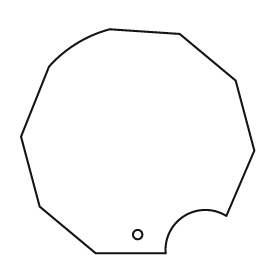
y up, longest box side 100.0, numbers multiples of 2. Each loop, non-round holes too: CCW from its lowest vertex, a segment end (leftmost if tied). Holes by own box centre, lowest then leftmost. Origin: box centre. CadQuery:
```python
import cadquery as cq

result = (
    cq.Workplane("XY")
    .moveTo(-18.0, -48.0)
    .lineTo(12.0, -48.0)
    .threePointArc((20.0, -32.0), (38.0, -32.0))
    .lineTo(50.0, -4.0)
    .lineTo(42.0, 26.0)
    .lineTo(18.0, 46.0)
    .lineTo(-12.0, 48.0)
    .threePointArc((-26.0, 42.0), (-38.0, 32.0))
    .lineTo(-50.0, 2.0)
    .lineTo(-42.0, -28.0)
    .close()
    .moveTo(0.0, -40.0)
    .circle(2.0)
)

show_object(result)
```